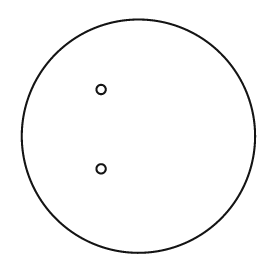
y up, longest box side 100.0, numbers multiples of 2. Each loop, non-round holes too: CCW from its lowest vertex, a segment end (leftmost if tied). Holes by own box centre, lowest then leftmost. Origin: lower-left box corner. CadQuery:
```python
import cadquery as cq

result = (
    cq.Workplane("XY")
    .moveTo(50.0, 50.0)
    .circle(50.0)
    .moveTo(34.0, 36.0)
    .circle(2.0)
    .moveTo(34.0, 70.0)
    .circle(2.0)
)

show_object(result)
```